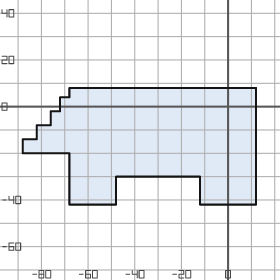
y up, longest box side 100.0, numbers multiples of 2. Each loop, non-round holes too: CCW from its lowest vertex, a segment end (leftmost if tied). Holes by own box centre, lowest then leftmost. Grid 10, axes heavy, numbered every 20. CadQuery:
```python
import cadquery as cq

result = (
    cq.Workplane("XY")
    .moveTo(-68.0, -42.0)
    .lineTo(-48.0, -42.0)
    .lineTo(-48.0, -30.0)
    .lineTo(-12.0, -30.0)
    .lineTo(-12.0, -42.0)
    .lineTo(12.0, -42.0)
    .lineTo(12.0, 8.0)
    .lineTo(-68.0, 8.0)
    .lineTo(-68.0, 4.0)
    .lineTo(-72.0, 4.0)
    .lineTo(-72.0, -2.0)
    .lineTo(-76.0, -2.0)
    .lineTo(-76.0, -8.0)
    .lineTo(-82.0, -8.0)
    .lineTo(-82.0, -14.0)
    .lineTo(-88.0, -14.0)
    .lineTo(-88.0, -20.0)
    .lineTo(-68.0, -20.0)
    .close()
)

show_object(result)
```